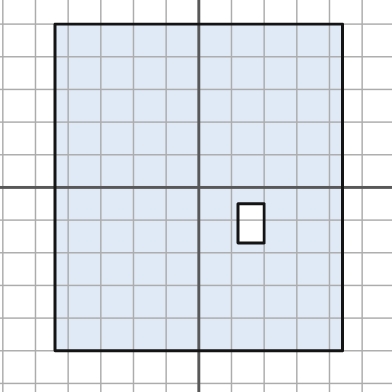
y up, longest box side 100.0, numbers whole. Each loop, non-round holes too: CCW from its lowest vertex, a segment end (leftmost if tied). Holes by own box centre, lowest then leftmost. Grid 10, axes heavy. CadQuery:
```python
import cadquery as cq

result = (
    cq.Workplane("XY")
    .moveTo(-44.0, -50.0)
    .lineTo(44.0, -50.0)
    .lineTo(44.0, 50.0)
    .lineTo(-44.0, 50.0)
    .close()
    .moveTo(12.0, -17.0)
    .lineTo(20.0, -17.0)
    .lineTo(20.0, -5.0)
    .lineTo(12.0, -5.0)
    .close()
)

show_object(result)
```